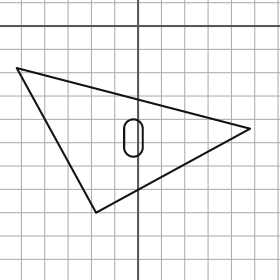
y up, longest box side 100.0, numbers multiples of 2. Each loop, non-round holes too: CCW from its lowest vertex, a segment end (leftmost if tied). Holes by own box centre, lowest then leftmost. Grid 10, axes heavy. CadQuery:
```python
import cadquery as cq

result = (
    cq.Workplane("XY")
    .moveTo(-18.0, -80.0)
    .lineTo(48.0, -44.0)
    .lineTo(-52.0, -18.0)
    .close()
    .moveTo(-6.0, -52.0)
    .threePointArc((-2.0, -56.0), (2.0, -52.0))
    .lineTo(2.0, -44.0)
    .threePointArc((-2.0, -40.0), (-6.0, -44.0))
    .close()
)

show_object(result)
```